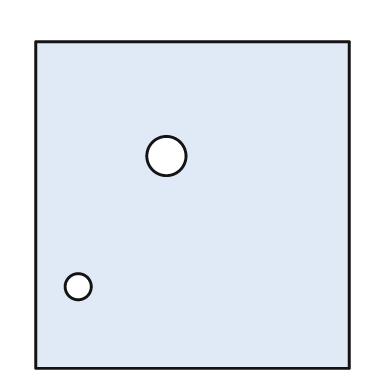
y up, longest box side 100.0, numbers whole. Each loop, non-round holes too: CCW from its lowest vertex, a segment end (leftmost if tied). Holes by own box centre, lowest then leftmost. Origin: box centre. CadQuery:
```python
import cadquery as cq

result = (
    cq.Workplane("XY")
    .moveTo(-48.0, -50.0)
    .lineTo(48.0, -50.0)
    .lineTo(48.0, 50.0)
    .lineTo(-48.0, 50.0)
    .close()
    .moveTo(-35.0, -25.0)
    .circle(4.0)
    .moveTo(-8.0, 15.0)
    .circle(6.0)
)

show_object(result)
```